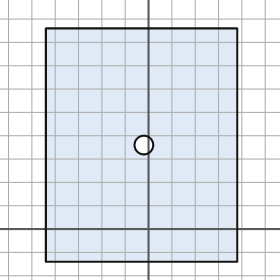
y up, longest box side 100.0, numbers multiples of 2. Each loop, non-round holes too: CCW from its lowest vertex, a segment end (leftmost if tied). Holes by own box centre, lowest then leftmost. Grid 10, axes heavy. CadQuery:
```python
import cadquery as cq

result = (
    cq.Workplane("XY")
    .moveTo(-44.0, -14.0)
    .lineTo(38.0, -14.0)
    .lineTo(38.0, 86.0)
    .lineTo(-44.0, 86.0)
    .close()
    .moveTo(-2.0, 36.0)
    .circle(4.0)
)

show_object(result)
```